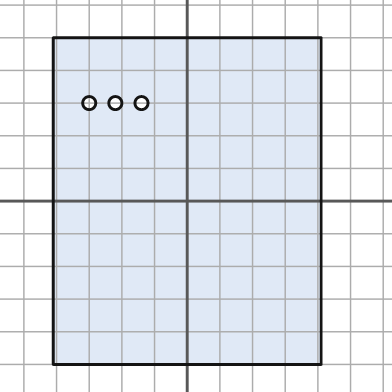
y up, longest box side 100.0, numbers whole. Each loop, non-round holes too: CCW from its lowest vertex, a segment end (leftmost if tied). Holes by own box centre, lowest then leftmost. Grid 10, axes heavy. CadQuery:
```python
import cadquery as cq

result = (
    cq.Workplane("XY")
    .moveTo(-41.0, -50.0)
    .lineTo(41.0, -50.0)
    .lineTo(41.0, 50.0)
    .lineTo(-41.0, 50.0)
    .close()
    .moveTo(-30.0, 30.0)
    .circle(2.0)
    .moveTo(-22.0, 30.0)
    .circle(2.0)
    .moveTo(-14.0, 30.0)
    .circle(2.0)
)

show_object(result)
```